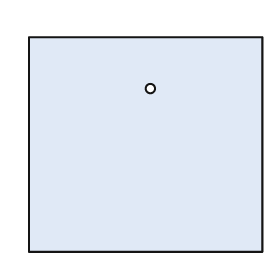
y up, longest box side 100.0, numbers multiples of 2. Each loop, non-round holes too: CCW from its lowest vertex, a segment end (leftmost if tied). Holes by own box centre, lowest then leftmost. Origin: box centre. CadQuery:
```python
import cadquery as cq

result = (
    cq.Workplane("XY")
    .moveTo(-50.0, -46.0)
    .lineTo(50.0, -46.0)
    .lineTo(50.0, 46.0)
    .lineTo(-50.0, 46.0)
    .close()
    .moveTo(2.0, 24.0)
    .circle(2.0)
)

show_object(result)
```